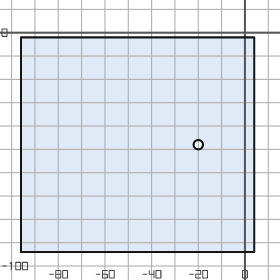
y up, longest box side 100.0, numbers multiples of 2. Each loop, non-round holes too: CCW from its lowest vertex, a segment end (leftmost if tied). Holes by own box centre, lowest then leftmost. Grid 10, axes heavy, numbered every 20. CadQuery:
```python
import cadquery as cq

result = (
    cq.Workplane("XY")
    .moveTo(-96.0, -94.0)
    .lineTo(4.0, -94.0)
    .lineTo(4.0, -2.0)
    .lineTo(-96.0, -2.0)
    .close()
    .moveTo(-20.0, -48.0)
    .circle(2.0)
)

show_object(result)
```